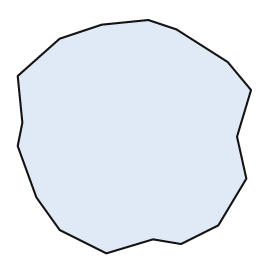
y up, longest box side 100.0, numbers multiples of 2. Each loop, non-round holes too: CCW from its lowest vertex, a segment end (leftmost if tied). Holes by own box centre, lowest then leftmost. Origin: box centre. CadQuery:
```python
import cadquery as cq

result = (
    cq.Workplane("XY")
    .moveTo(-12.0, -50.0)
    .lineTo(8.0, -44.0)
    .lineTo(20.0, -46.0)
    .lineTo(36.0, -38.0)
    .lineTo(48.0, -18.0)
    .lineTo(44.0, 0.0)
    .lineTo(50.0, 20.0)
    .lineTo(40.0, 32.0)
    .lineTo(18.0, 46.0)
    .lineTo(6.0, 50.0)
    .lineTo(-14.0, 48.0)
    .lineTo(-32.0, 42.0)
    .lineTo(-50.0, 26.0)
    .lineTo(-48.0, 6.0)
    .lineTo(-50.0, -4.0)
    .lineTo(-42.0, -26.0)
    .lineTo(-32.0, -40.0)
    .close()
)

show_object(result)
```